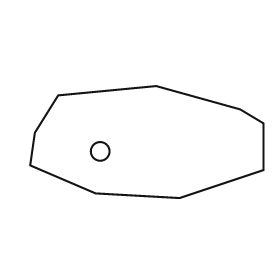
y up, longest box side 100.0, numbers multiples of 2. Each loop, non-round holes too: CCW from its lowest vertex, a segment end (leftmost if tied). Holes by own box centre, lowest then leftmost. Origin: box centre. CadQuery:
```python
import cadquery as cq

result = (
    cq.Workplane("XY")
    .moveTo(14.0, -24.0)
    .lineTo(50.0, -12.0)
    .lineTo(50.0, 8.0)
    .lineTo(40.0, 14.0)
    .lineTo(4.0, 24.0)
    .lineTo(-38.0, 20.0)
    .lineTo(-48.0, 4.0)
    .lineTo(-50.0, -10.0)
    .lineTo(-22.0, -22.0)
    .close()
    .moveTo(-20.0, -4.0)
    .circle(4.0)
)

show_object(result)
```